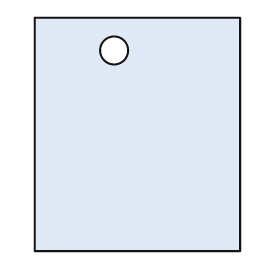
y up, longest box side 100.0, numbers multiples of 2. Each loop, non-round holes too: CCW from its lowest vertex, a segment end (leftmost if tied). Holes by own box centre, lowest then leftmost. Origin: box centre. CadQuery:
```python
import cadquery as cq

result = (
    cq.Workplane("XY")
    .moveTo(-44.0, -50.0)
    .lineTo(44.0, -50.0)
    .lineTo(44.0, 50.0)
    .lineTo(-44.0, 50.0)
    .close()
    .moveTo(-10.0, 36.0)
    .circle(6.0)
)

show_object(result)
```